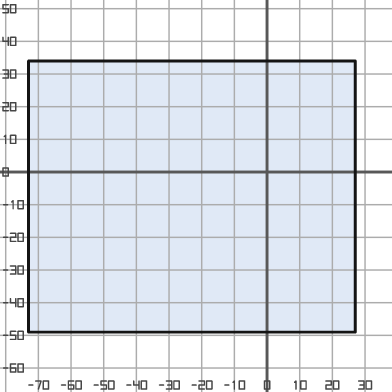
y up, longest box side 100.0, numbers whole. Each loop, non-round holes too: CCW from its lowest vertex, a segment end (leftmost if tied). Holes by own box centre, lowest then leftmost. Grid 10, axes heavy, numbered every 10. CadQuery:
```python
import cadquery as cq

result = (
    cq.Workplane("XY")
    .moveTo(-73.0, -49.0)
    .lineTo(27.0, -49.0)
    .lineTo(27.0, 34.0)
    .lineTo(-73.0, 34.0)
    .close()
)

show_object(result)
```